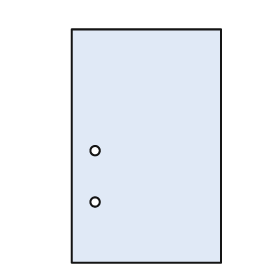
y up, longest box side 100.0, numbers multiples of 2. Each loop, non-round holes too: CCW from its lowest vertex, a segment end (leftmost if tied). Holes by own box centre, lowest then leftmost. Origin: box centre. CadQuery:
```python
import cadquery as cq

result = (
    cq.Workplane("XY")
    .moveTo(-32.0, -50.0)
    .lineTo(32.0, -50.0)
    .lineTo(32.0, 50.0)
    .lineTo(-32.0, 50.0)
    .close()
    .moveTo(-22.0, -24.0)
    .circle(2.0)
    .moveTo(-22.0, -2.0)
    .circle(2.0)
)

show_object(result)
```